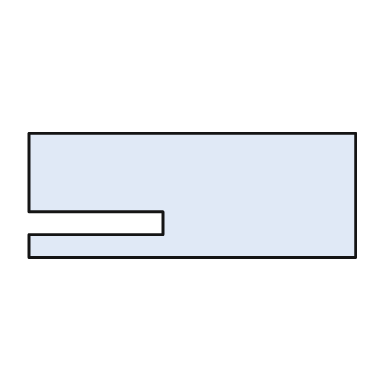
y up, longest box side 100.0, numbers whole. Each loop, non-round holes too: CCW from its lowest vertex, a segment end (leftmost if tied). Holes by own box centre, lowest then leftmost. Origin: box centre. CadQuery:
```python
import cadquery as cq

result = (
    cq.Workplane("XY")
    .moveTo(-50.0, -19.0)
    .lineTo(50.0, -19.0)
    .lineTo(50.0, 19.0)
    .lineTo(-50.0, 19.0)
    .lineTo(-50.0, -5.0)
    .lineTo(-9.0, -5.0)
    .lineTo(-9.0, -12.0)
    .lineTo(-50.0, -12.0)
    .close()
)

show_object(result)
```